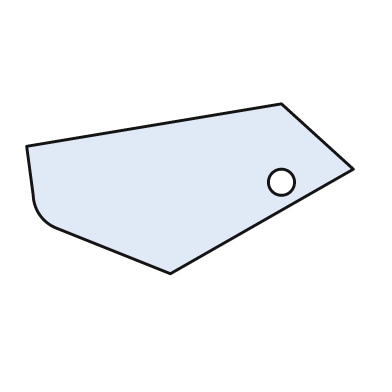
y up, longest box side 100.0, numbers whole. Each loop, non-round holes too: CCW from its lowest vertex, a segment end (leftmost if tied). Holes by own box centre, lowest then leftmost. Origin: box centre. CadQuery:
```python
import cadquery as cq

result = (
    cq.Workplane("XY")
    .moveTo(-6.0, -26.0)
    .lineTo(50.0, 6.0)
    .lineTo(28.0, 26.0)
    .lineTo(-50.0, 13.0)
    .lineTo(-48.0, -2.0)
    .threePointArc((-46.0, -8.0), (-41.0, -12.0))
    .close()
    .moveTo(28.0, 2.0)
    .circle(4.0)
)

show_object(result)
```